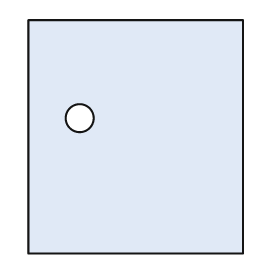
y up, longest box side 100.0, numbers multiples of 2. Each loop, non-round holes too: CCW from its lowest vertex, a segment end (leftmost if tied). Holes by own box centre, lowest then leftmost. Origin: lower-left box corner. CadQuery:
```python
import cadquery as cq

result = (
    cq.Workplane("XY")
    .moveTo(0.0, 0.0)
    .lineTo(92.0, 0.0)
    .lineTo(92.0, 100.0)
    .lineTo(0.0, 100.0)
    .close()
    .moveTo(22.0, 58.0)
    .circle(6.0)
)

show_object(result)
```